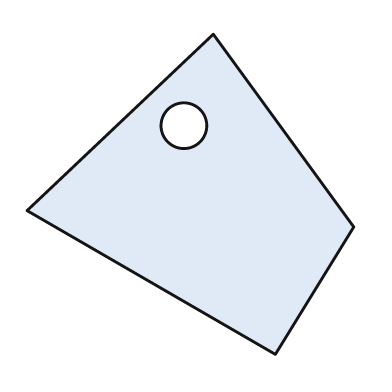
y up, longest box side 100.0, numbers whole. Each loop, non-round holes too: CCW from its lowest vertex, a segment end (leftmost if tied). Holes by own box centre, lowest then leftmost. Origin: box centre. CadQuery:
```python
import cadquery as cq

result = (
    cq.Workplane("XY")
    .moveTo(26.0, -49.0)
    .lineTo(50.0, -10.0)
    .lineTo(7.0, 49.0)
    .lineTo(-50.0, -5.0)
    .close()
    .moveTo(-2.0, 21.0)
    .circle(7.0)
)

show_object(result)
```